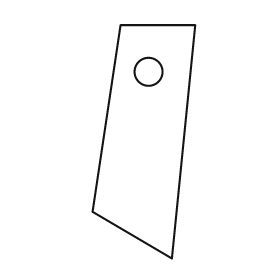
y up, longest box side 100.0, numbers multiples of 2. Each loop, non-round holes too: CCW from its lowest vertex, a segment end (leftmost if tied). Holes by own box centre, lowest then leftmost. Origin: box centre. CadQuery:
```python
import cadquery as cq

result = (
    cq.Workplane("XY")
    .moveTo(12.0, -50.0)
    .lineTo(22.0, 50.0)
    .lineTo(-10.0, 50.0)
    .lineTo(-22.0, -30.0)
    .close()
    .moveTo(2.0, 30.0)
    .circle(6.0)
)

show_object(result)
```